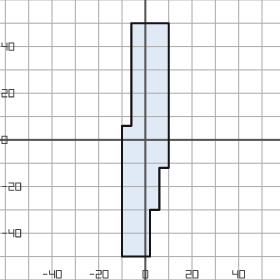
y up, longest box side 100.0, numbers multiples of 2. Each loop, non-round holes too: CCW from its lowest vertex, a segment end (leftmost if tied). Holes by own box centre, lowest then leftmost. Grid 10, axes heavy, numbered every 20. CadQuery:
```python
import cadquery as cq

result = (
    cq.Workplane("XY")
    .moveTo(-10.0, -50.0)
    .lineTo(2.0, -50.0)
    .lineTo(2.0, -30.0)
    .lineTo(6.0, -30.0)
    .lineTo(6.0, -12.0)
    .lineTo(10.0, -12.0)
    .lineTo(10.0, 50.0)
    .lineTo(-6.0, 50.0)
    .lineTo(-6.0, 6.0)
    .lineTo(-10.0, 6.0)
    .close()
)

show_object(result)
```